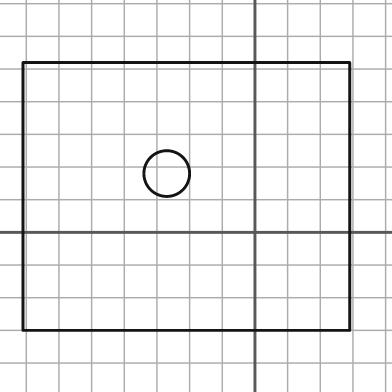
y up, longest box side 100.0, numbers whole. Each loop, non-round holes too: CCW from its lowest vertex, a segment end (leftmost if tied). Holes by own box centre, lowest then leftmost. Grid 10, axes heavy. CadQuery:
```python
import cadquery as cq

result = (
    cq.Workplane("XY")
    .moveTo(-71.0, -30.0)
    .lineTo(29.0, -30.0)
    .lineTo(29.0, 52.0)
    .lineTo(-71.0, 52.0)
    .close()
    .moveTo(-27.0, 18.0)
    .circle(7.0)
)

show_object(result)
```